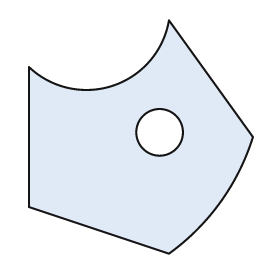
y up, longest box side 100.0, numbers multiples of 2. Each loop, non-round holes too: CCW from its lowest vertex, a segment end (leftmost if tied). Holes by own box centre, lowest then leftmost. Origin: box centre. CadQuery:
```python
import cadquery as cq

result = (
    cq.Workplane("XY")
    .moveTo(12.0, -50.0)
    .threePointArc((34.0, -28.0), (48.0, 0.0))
    .lineTo(12.0, 50.0)
    .threePointArc((-12.0, 22.0), (-48.0, 30.0))
    .lineTo(-48.0, -30.0)
    .close()
    .moveTo(8.0, 2.0)
    .circle(10.0)
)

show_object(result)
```